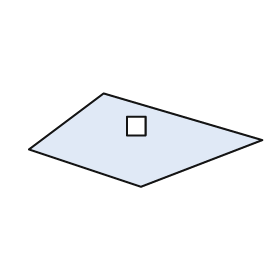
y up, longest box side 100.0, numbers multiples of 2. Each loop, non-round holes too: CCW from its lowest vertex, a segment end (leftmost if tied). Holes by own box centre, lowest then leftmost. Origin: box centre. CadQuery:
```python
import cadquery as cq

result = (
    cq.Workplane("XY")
    .moveTo(-2.0, -20.0)
    .lineTo(50.0, 0.0)
    .lineTo(-18.0, 20.0)
    .lineTo(-50.0, -4.0)
    .close()
    .moveTo(-8.0, 2.0)
    .lineTo(0.0, 2.0)
    .lineTo(0.0, 10.0)
    .lineTo(-8.0, 10.0)
    .close()
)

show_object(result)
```